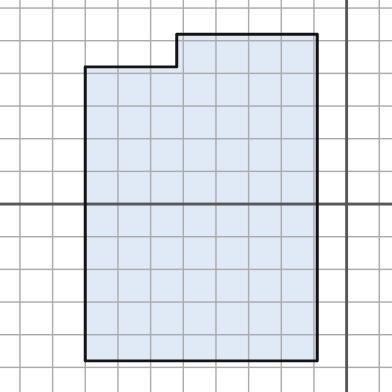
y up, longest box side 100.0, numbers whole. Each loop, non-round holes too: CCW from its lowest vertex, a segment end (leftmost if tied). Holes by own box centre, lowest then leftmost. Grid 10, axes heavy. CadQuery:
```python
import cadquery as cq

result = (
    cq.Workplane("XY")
    .moveTo(-80.0, -48.0)
    .lineTo(-9.0, -48.0)
    .lineTo(-9.0, 52.0)
    .lineTo(-52.0, 52.0)
    .lineTo(-52.0, 42.0)
    .lineTo(-80.0, 42.0)
    .close()
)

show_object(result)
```